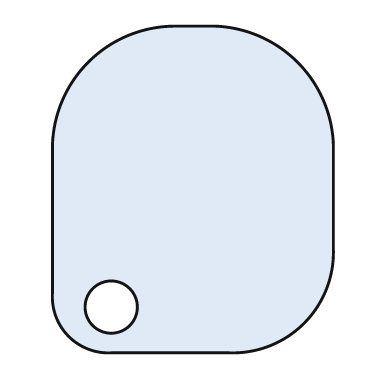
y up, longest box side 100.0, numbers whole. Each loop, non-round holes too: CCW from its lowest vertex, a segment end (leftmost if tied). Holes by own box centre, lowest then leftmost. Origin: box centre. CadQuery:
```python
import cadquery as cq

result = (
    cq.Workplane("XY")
    .moveTo(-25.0, -50.0)
    .lineTo(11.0, -50.0)
    .threePointArc((34.0, -41.0), (43.0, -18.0))
    .lineTo(43.0, 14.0)
    .threePointArc((32.0, 39.0), (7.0, 50.0))
    .lineTo(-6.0, 50.0)
    .threePointArc((-32.0, 39.0), (-43.0, 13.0))
    .lineTo(-43.0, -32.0)
    .threePointArc((-38.0, -45.0), (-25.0, -50.0))
    .close()
    .moveTo(-25.0, -36.0)
    .circle(8.0)
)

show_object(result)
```